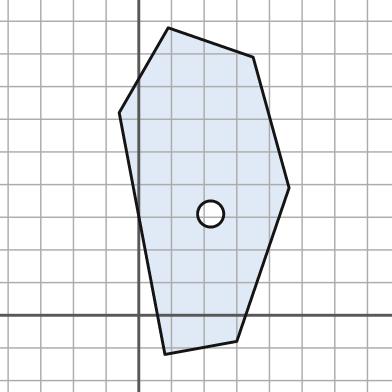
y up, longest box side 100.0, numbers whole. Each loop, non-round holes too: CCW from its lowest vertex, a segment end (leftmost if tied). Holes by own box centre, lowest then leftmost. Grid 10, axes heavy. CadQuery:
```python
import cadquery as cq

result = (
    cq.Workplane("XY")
    .moveTo(8.0, -12.0)
    .lineTo(30.0, -8.0)
    .lineTo(46.0, 39.0)
    .lineTo(35.0, 79.0)
    .lineTo(9.0, 88.0)
    .lineTo(-6.0, 62.0)
    .close()
    .moveTo(22.0, 31.0)
    .circle(4.0)
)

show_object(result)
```